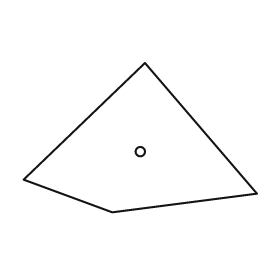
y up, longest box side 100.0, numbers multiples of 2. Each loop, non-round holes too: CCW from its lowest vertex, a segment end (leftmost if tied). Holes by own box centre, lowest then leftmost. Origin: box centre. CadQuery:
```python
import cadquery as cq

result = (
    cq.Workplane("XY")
    .moveTo(-12.0, -32.0)
    .lineTo(50.0, -24.0)
    .lineTo(2.0, 32.0)
    .lineTo(-50.0, -18.0)
    .close()
    .moveTo(0.0, -6.0)
    .circle(2.0)
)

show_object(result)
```